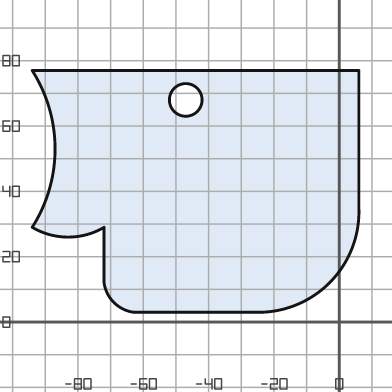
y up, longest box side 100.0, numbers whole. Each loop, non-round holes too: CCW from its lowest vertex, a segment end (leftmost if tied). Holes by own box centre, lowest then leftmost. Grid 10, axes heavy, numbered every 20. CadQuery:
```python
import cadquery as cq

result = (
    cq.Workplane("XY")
    .moveTo(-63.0, 3.0)
    .lineTo(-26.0, 3.0)
    .threePointArc((-3.0, 12.0), (6.0, 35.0))
    .lineTo(6.0, 77.0)
    .lineTo(-94.0, 77.0)
    .threePointArc((-87.0, 53.0), (-94.0, 29.0))
    .threePointArc((-83.0, 26.0), (-72.0, 29.0))
    .lineTo(-72.0, 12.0)
    .threePointArc((-69.0, 6.0), (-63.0, 3.0))
    .close()
    .moveTo(-47.0, 68.0)
    .circle(5.0)
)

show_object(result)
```